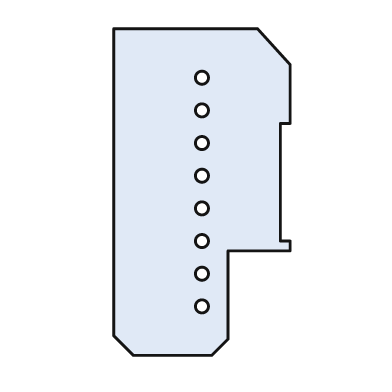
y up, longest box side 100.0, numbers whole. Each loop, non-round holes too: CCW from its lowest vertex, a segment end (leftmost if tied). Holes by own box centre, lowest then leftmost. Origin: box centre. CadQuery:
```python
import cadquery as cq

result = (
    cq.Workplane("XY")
    .moveTo(-21.0, -50.0)
    .lineTo(3.0, -50.0)
    .lineTo(8.0, -45.0)
    .lineTo(8.0, -18.0)
    .lineTo(27.0, -18.0)
    .lineTo(27.0, -15.0)
    .lineTo(24.0, -15.0)
    .lineTo(24.0, 21.0)
    .lineTo(27.0, 21.0)
    .lineTo(27.0, 39.0)
    .lineTo(17.0, 50.0)
    .lineTo(-27.0, 50.0)
    .lineTo(-27.0, -44.0)
    .close()
    .moveTo(0.0, -35.0)
    .circle(2.0)
    .moveTo(0.0, -25.0)
    .circle(2.0)
    .moveTo(0.0, -15.0)
    .circle(2.0)
    .moveTo(0.0, -5.0)
    .circle(2.0)
    .moveTo(0.0, 5.0)
    .circle(2.0)
    .moveTo(0.0, 15.0)
    .circle(2.0)
    .moveTo(0.0, 25.0)
    .circle(2.0)
    .moveTo(0.0, 35.0)
    .circle(2.0)
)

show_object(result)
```